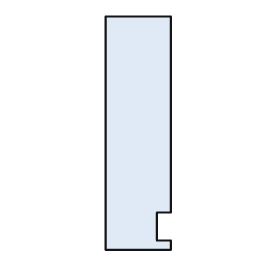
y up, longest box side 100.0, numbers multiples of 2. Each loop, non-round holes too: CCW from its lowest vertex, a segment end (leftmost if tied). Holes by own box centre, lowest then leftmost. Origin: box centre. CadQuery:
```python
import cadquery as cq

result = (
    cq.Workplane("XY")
    .moveTo(-14.0, -50.0)
    .lineTo(14.0, -50.0)
    .lineTo(14.0, -46.0)
    .lineTo(8.0, -46.0)
    .lineTo(8.0, -34.0)
    .lineTo(14.0, -34.0)
    .lineTo(14.0, 50.0)
    .lineTo(-14.0, 50.0)
    .close()
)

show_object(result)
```